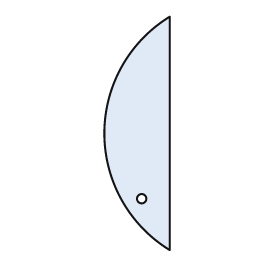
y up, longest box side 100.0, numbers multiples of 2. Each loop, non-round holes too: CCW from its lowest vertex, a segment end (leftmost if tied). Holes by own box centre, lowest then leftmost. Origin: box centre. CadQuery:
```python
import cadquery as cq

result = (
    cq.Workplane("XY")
    .moveTo(14.0, -50.0)
    .lineTo(14.0, 50.0)
    .threePointArc((-14.0, 0.0), (14.0, -50.0))
    .close()
    .moveTo(2.0, -28.0)
    .circle(2.0)
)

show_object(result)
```